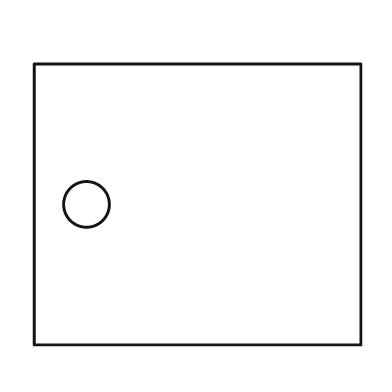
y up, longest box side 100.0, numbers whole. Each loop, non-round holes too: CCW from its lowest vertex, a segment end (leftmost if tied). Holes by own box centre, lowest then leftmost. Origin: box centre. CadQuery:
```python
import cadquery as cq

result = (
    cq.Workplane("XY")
    .moveTo(-50.0, -43.0)
    .lineTo(50.0, -43.0)
    .lineTo(50.0, 43.0)
    .lineTo(-50.0, 43.0)
    .close()
    .moveTo(-34.0, 0.0)
    .circle(7.0)
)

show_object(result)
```